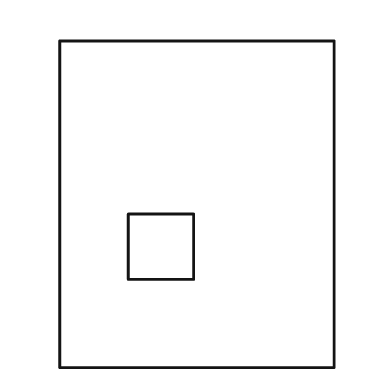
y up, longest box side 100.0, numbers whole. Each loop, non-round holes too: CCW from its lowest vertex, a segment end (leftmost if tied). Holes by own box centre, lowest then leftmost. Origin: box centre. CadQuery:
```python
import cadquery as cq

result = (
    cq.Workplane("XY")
    .moveTo(-42.0, -50.0)
    .lineTo(42.0, -50.0)
    .lineTo(42.0, 50.0)
    .lineTo(-42.0, 50.0)
    .close()
    .moveTo(-21.0, -23.0)
    .lineTo(-1.0, -23.0)
    .lineTo(-1.0, -3.0)
    .lineTo(-21.0, -3.0)
    .close()
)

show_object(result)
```